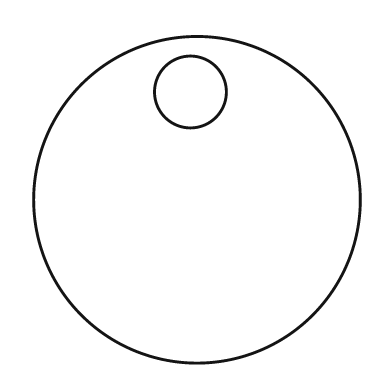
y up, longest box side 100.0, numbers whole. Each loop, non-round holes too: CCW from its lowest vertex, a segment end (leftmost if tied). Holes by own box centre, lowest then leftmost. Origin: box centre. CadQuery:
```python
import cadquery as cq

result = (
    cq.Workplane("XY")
    .moveTo(0.0, 0.0)
    .circle(50.0)
    .moveTo(-2.0, 33.0)
    .circle(11.0)
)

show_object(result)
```